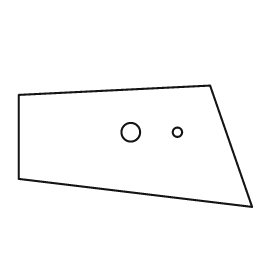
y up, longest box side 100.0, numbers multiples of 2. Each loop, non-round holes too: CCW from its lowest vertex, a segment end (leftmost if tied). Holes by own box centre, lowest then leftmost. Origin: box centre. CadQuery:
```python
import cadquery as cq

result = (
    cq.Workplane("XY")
    .moveTo(50.0, -26.0)
    .lineTo(32.0, 26.0)
    .lineTo(-50.0, 22.0)
    .lineTo(-50.0, -14.0)
    .close()
    .moveTo(-2.0, 6.0)
    .circle(4.0)
    .moveTo(18.0, 6.0)
    .circle(2.0)
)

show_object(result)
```